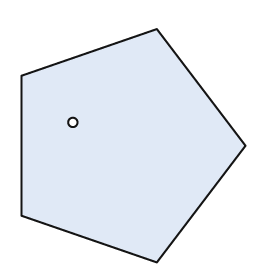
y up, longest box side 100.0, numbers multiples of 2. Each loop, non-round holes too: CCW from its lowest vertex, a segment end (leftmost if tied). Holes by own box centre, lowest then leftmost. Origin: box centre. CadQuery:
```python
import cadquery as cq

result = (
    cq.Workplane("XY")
    .moveTo(10.0, -50.0)
    .lineTo(48.0, 0.0)
    .lineTo(10.0, 50.0)
    .lineTo(-48.0, 30.0)
    .lineTo(-48.0, -30.0)
    .close()
    .moveTo(-26.0, 10.0)
    .circle(2.0)
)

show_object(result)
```